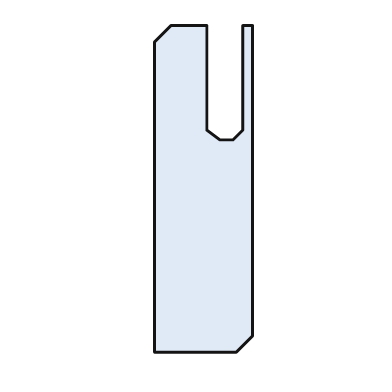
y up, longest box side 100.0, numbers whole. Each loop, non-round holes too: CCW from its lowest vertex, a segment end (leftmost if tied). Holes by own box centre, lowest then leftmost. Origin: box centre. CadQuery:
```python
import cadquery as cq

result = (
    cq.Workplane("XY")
    .moveTo(-15.0, -50.0)
    .lineTo(10.0, -50.0)
    .lineTo(15.0, -45.0)
    .lineTo(15.0, 50.0)
    .lineTo(12.0, 50.0)
    .lineTo(12.0, 18.0)
    .lineTo(9.0, 15.0)
    .lineTo(5.0, 15.0)
    .lineTo(1.0, 18.0)
    .lineTo(1.0, 50.0)
    .lineTo(-10.0, 50.0)
    .lineTo(-15.0, 45.0)
    .close()
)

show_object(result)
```